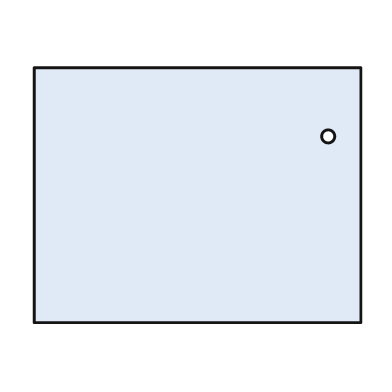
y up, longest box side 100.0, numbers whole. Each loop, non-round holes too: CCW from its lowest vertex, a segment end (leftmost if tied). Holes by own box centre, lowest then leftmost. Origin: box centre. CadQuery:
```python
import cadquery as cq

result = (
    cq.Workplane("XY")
    .moveTo(-50.0, -39.0)
    .lineTo(50.0, -39.0)
    .lineTo(50.0, 39.0)
    .lineTo(-50.0, 39.0)
    .close()
    .moveTo(40.0, 18.0)
    .circle(2.0)
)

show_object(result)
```